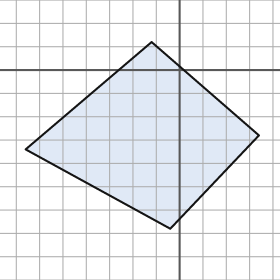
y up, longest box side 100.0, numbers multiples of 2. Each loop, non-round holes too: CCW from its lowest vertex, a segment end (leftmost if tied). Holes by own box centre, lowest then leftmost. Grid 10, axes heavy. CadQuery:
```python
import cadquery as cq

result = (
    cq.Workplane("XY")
    .moveTo(-4.0, -68.0)
    .lineTo(34.0, -28.0)
    .lineTo(-12.0, 12.0)
    .lineTo(-66.0, -34.0)
    .close()
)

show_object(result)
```